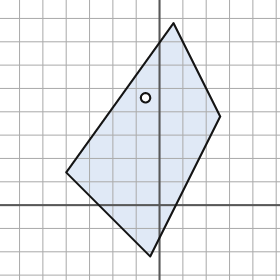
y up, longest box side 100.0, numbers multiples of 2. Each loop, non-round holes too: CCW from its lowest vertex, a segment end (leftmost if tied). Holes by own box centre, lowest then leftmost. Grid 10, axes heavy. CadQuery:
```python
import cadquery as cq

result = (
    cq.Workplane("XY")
    .moveTo(-4.0, -22.0)
    .lineTo(26.0, 38.0)
    .lineTo(6.0, 78.0)
    .lineTo(-40.0, 14.0)
    .close()
    .moveTo(-6.0, 46.0)
    .circle(2.0)
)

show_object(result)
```